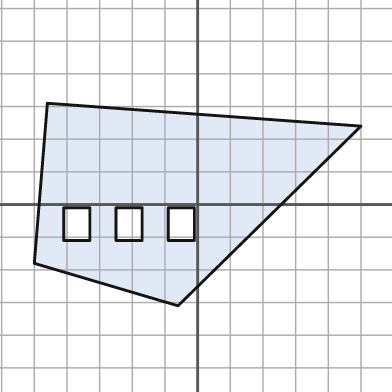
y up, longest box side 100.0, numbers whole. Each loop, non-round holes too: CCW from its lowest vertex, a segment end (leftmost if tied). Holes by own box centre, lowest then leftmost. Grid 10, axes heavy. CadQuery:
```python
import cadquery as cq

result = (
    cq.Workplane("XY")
    .moveTo(-6.0, -31.0)
    .lineTo(50.0, 24.0)
    .lineTo(-46.0, 31.0)
    .lineTo(-50.0, -18.0)
    .close()
    .moveTo(-41.0, -11.0)
    .lineTo(-33.0, -11.0)
    .lineTo(-33.0, -1.0)
    .lineTo(-41.0, -1.0)
    .close()
    .moveTo(-25.0, -11.0)
    .lineTo(-17.0, -11.0)
    .lineTo(-17.0, -1.0)
    .lineTo(-25.0, -1.0)
    .close()
    .moveTo(-9.0, -11.0)
    .lineTo(-1.0, -11.0)
    .lineTo(-1.0, -1.0)
    .lineTo(-9.0, -1.0)
    .close()
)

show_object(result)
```